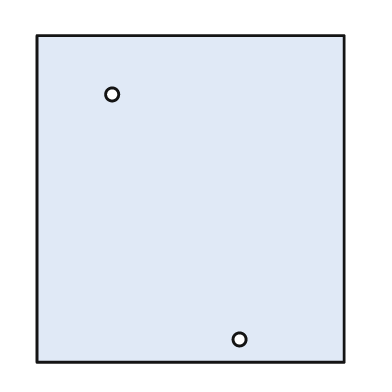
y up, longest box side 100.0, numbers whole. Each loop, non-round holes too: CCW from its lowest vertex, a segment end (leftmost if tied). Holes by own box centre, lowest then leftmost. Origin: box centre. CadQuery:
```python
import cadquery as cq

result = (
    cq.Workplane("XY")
    .moveTo(-47.0, -50.0)
    .lineTo(47.0, -50.0)
    .lineTo(47.0, 50.0)
    .lineTo(-47.0, 50.0)
    .close()
    .moveTo(15.0, -43.0)
    .circle(2.0)
    .moveTo(-24.0, 32.0)
    .circle(2.0)
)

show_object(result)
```